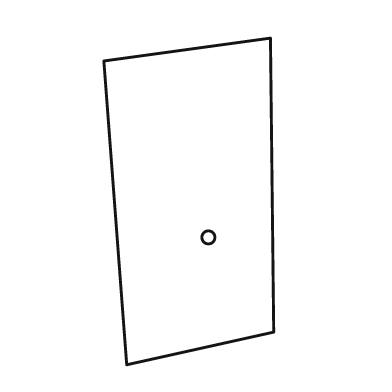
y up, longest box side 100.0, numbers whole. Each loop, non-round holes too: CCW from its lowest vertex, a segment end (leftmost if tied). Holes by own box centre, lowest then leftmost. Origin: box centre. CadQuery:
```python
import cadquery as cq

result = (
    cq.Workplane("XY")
    .moveTo(-19.0, -50.0)
    .lineTo(26.0, -40.0)
    .lineTo(25.0, 50.0)
    .lineTo(-26.0, 43.0)
    .close()
    .moveTo(6.0, -11.0)
    .circle(2.0)
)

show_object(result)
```